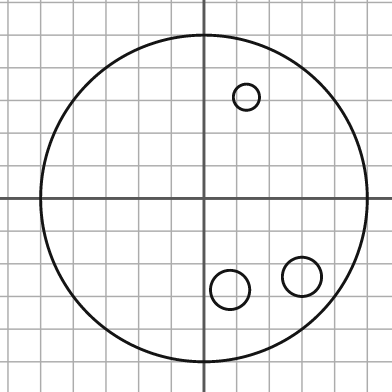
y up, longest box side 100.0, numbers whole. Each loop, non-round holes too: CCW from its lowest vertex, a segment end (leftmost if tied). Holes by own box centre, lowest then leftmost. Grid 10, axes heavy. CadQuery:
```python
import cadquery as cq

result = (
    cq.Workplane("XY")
    .moveTo(0.0, 0.0)
    .circle(50.0)
    .moveTo(8.0, -28.0)
    .circle(6.0)
    .moveTo(30.0, -24.0)
    .circle(6.0)
    .moveTo(13.0, 31.0)
    .circle(4.0)
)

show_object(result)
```